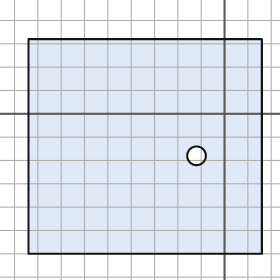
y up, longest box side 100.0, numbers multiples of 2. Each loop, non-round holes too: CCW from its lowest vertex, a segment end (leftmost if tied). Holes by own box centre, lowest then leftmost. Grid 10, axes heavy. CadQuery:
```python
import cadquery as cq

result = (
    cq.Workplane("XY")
    .moveTo(-84.0, -60.0)
    .lineTo(16.0, -60.0)
    .lineTo(16.0, 32.0)
    .lineTo(-84.0, 32.0)
    .close()
    .moveTo(-12.0, -18.0)
    .circle(4.0)
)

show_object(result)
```